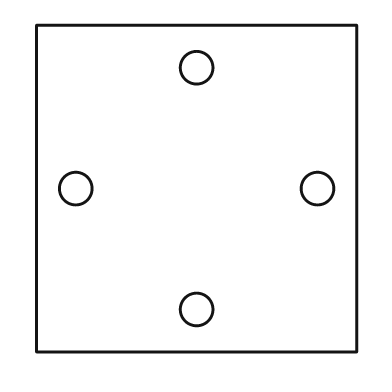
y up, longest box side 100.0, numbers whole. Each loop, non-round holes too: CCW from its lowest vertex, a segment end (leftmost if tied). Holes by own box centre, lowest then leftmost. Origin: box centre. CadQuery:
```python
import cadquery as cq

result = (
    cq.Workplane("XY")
    .moveTo(-49.0, -50.0)
    .lineTo(49.0, -50.0)
    .lineTo(49.0, 50.0)
    .lineTo(-49.0, 50.0)
    .close()
    .moveTo(0.0, -37.0)
    .circle(5.0)
    .moveTo(-37.0, 0.0)
    .circle(5.0)
    .moveTo(37.0, 0.0)
    .circle(5.0)
    .moveTo(0.0, 37.0)
    .circle(5.0)
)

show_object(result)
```